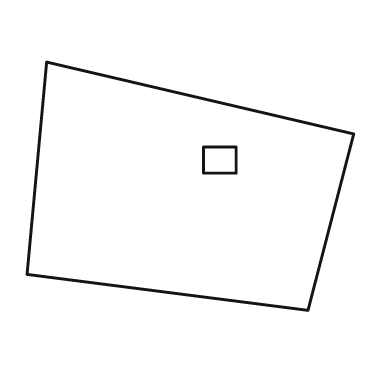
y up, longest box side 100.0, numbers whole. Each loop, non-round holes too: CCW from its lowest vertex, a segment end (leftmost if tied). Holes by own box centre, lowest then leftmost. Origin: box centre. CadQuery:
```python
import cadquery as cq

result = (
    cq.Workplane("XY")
    .moveTo(36.0, -38.0)
    .lineTo(50.0, 16.0)
    .lineTo(-44.0, 38.0)
    .lineTo(-50.0, -27.0)
    .close()
    .moveTo(4.0, 4.0)
    .lineTo(14.0, 4.0)
    .lineTo(14.0, 12.0)
    .lineTo(4.0, 12.0)
    .close()
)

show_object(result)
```